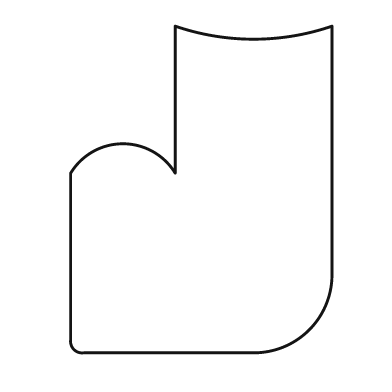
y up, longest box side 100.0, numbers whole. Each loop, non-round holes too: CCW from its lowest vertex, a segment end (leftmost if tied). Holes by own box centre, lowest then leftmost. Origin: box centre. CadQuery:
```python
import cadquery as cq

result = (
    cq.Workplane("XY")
    .moveTo(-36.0, -50.0)
    .lineTo(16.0, -50.0)
    .threePointArc((33.0, -43.0), (40.0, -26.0))
    .lineTo(40.0, 50.0)
    .threePointArc((16.0, 46.0), (-8.0, 50.0))
    .lineTo(-8.0, 5.0)
    .threePointArc((-24.0, 14.0), (-40.0, 5.0))
    .lineTo(-40.0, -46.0)
    .threePointArc((-39.0, -49.0), (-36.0, -50.0))
    .close()
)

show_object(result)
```